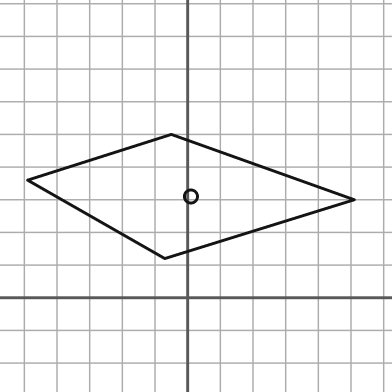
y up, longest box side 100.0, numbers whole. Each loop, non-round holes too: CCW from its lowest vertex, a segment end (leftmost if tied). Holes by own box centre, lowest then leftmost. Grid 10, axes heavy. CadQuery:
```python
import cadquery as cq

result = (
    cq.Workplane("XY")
    .moveTo(-7.0, 12.0)
    .lineTo(51.0, 30.0)
    .lineTo(-5.0, 50.0)
    .lineTo(-49.0, 36.0)
    .close()
    .moveTo(1.0, 31.0)
    .circle(2.0)
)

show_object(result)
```